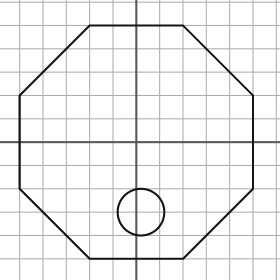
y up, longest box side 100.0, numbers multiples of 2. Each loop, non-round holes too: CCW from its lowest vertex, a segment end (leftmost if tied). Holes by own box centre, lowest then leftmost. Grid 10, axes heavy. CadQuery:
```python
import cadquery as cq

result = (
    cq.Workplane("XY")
    .moveTo(-20.0, -50.0)
    .lineTo(20.0, -50.0)
    .lineTo(50.0, -20.0)
    .lineTo(50.0, 20.0)
    .lineTo(20.0, 50.0)
    .lineTo(-20.0, 50.0)
    .lineTo(-50.0, 20.0)
    .lineTo(-50.0, -20.0)
    .close()
    .moveTo(2.0, -30.0)
    .circle(10.0)
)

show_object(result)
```